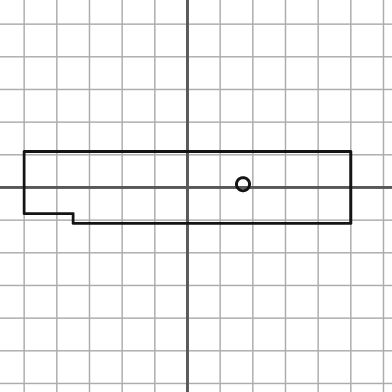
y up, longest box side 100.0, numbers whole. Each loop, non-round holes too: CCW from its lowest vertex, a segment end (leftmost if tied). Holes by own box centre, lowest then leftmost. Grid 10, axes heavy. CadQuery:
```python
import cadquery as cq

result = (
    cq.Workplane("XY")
    .moveTo(-35.0, -11.0)
    .lineTo(50.0, -11.0)
    .lineTo(50.0, 11.0)
    .lineTo(-50.0, 11.0)
    .lineTo(-50.0, -8.0)
    .lineTo(-35.0, -8.0)
    .close()
    .moveTo(17.0, 1.0)
    .circle(2.0)
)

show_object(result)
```